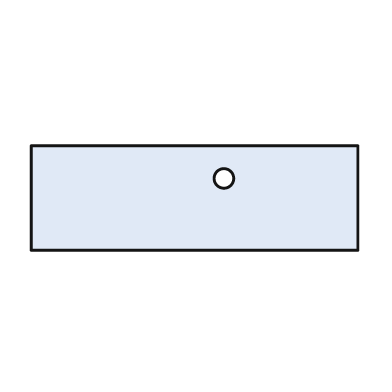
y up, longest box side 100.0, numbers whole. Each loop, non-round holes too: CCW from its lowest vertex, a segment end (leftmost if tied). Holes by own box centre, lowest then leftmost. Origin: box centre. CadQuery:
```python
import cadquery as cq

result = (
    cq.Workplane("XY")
    .moveTo(-50.0, -16.0)
    .lineTo(50.0, -16.0)
    .lineTo(50.0, 16.0)
    .lineTo(-50.0, 16.0)
    .close()
    .moveTo(9.0, 6.0)
    .circle(3.0)
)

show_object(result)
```